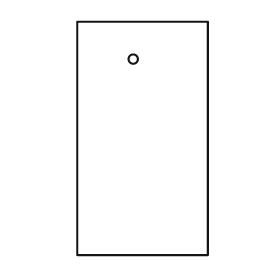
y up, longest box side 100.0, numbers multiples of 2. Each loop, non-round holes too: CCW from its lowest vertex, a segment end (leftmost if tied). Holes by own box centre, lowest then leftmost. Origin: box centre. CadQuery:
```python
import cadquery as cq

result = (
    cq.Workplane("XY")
    .moveTo(-28.0, -50.0)
    .lineTo(28.0, -50.0)
    .lineTo(28.0, 50.0)
    .lineTo(-28.0, 50.0)
    .close()
    .moveTo(-4.0, 34.0)
    .circle(2.0)
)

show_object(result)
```